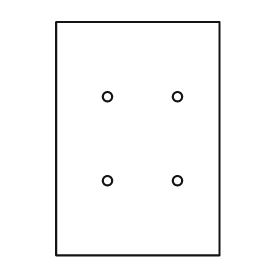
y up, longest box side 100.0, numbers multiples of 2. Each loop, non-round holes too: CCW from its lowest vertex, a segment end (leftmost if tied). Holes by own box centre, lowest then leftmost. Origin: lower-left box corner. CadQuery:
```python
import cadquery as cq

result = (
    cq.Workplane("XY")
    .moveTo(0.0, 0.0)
    .lineTo(70.0, 0.0)
    .lineTo(70.0, 100.0)
    .lineTo(0.0, 100.0)
    .close()
    .moveTo(22.0, 32.0)
    .circle(2.0)
    .moveTo(52.0, 32.0)
    .circle(2.0)
    .moveTo(22.0, 68.0)
    .circle(2.0)
    .moveTo(52.0, 68.0)
    .circle(2.0)
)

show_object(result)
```